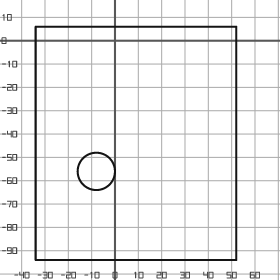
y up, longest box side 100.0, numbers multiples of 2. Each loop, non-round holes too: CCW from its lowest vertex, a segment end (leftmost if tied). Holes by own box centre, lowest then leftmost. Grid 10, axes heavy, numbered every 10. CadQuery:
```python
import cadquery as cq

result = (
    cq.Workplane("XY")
    .moveTo(-34.0, -94.0)
    .lineTo(52.0, -94.0)
    .lineTo(52.0, 6.0)
    .lineTo(-34.0, 6.0)
    .close()
    .moveTo(-8.0, -56.0)
    .circle(8.0)
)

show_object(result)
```